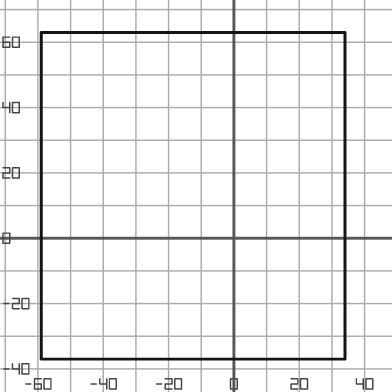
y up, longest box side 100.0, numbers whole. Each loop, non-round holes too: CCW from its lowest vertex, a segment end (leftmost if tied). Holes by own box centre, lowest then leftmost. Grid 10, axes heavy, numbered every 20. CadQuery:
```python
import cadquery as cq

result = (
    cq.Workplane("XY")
    .moveTo(-59.0, -37.0)
    .lineTo(34.0, -37.0)
    .lineTo(34.0, 63.0)
    .lineTo(-59.0, 63.0)
    .close()
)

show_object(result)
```